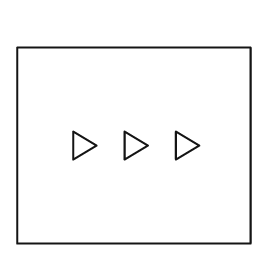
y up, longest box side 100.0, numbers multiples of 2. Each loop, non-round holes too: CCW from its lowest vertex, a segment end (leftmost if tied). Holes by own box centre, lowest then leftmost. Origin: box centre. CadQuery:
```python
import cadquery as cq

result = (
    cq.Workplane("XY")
    .moveTo(-50.0, -42.0)
    .lineTo(50.0, -42.0)
    .lineTo(50.0, 42.0)
    .lineTo(-50.0, 42.0)
    .close()
    .moveTo(-26.0, -6.0)
    .lineTo(-16.0, 0.0)
    .lineTo(-26.0, 6.0)
    .close()
    .moveTo(-4.0, -6.0)
    .lineTo(6.0, 0.0)
    .lineTo(-4.0, 6.0)
    .close()
    .moveTo(18.0, -6.0)
    .lineTo(28.0, 0.0)
    .lineTo(18.0, 6.0)
    .close()
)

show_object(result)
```